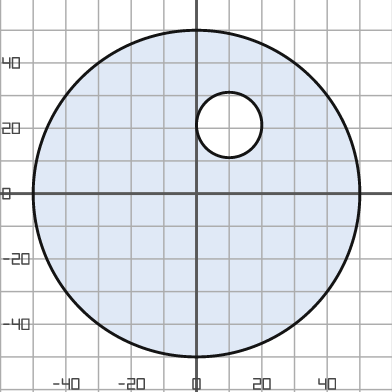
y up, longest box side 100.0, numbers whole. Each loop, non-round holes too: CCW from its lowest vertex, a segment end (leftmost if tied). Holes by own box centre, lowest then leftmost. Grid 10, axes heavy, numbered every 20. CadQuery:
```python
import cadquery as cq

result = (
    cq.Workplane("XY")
    .moveTo(0.0, 0.0)
    .circle(50.0)
    .moveTo(10.0, 21.0)
    .circle(10.0)
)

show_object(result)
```